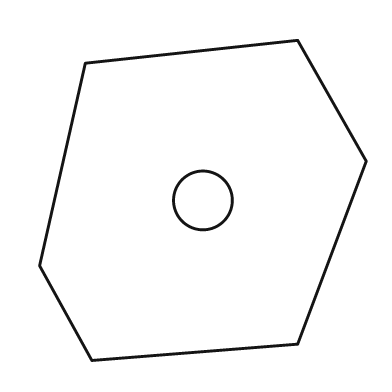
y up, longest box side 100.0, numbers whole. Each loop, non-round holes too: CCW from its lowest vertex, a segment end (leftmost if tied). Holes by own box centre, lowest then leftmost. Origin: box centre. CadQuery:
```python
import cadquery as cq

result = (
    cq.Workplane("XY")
    .moveTo(-34.0, -49.0)
    .lineTo(29.0, -44.0)
    .lineTo(50.0, 12.0)
    .lineTo(29.0, 49.0)
    .lineTo(-36.0, 42.0)
    .lineTo(-50.0, -20.0)
    .close()
    .moveTo(0.0, 0.0)
    .circle(9.0)
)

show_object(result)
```